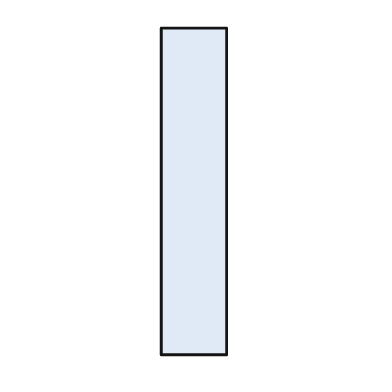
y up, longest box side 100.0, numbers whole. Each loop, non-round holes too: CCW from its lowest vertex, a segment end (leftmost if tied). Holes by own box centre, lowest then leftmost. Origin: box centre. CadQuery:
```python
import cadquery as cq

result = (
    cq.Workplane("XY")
    .moveTo(-10.0, -50.0)
    .lineTo(10.0, -50.0)
    .lineTo(10.0, 50.0)
    .lineTo(-10.0, 50.0)
    .close()
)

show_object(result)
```